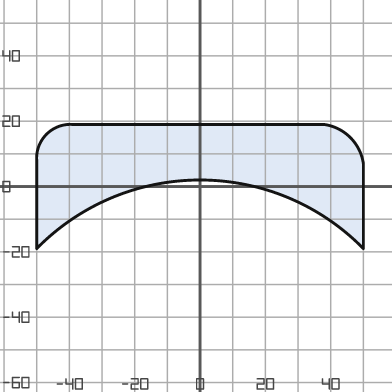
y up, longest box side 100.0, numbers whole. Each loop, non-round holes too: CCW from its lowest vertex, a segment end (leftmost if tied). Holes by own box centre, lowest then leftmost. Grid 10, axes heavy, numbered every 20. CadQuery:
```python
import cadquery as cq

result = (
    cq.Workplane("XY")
    .moveTo(-50.0, -19.0)
    .threePointArc((0.0, 2.0), (50.0, -19.0))
    .lineTo(50.0, 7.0)
    .threePointArc((46.0, 15.0), (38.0, 19.0))
    .lineTo(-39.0, 19.0)
    .threePointArc((-47.0, 16.0), (-50.0, 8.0))
    .close()
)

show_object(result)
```